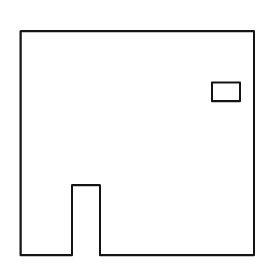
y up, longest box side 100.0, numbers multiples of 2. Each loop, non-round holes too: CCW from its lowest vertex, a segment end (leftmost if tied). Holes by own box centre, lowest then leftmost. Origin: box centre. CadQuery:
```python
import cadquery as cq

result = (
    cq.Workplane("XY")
    .moveTo(-50.0, -48.0)
    .lineTo(-28.0, -48.0)
    .lineTo(-28.0, -18.0)
    .lineTo(-16.0, -18.0)
    .lineTo(-16.0, -48.0)
    .lineTo(50.0, -48.0)
    .lineTo(50.0, 48.0)
    .lineTo(-50.0, 48.0)
    .close()
    .moveTo(32.0, 18.0)
    .lineTo(44.0, 18.0)
    .lineTo(44.0, 26.0)
    .lineTo(32.0, 26.0)
    .close()
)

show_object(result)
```